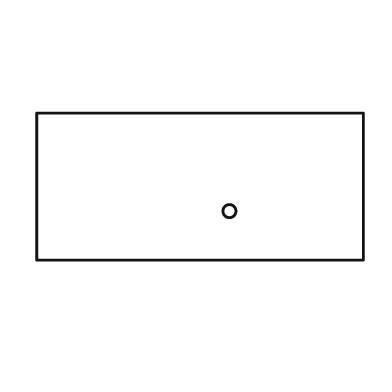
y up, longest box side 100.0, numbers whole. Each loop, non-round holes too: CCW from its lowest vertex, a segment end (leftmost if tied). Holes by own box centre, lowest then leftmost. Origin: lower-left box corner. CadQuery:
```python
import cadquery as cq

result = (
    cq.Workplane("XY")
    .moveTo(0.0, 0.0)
    .lineTo(100.0, 0.0)
    .lineTo(100.0, 45.0)
    .lineTo(0.0, 45.0)
    .close()
    .moveTo(59.0, 15.0)
    .circle(2.0)
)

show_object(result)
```